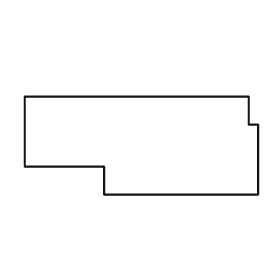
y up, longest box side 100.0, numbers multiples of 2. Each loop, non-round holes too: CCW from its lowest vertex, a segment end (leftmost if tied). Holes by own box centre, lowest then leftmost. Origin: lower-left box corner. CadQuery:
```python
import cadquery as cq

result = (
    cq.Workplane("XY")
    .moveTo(34.0, 0.0)
    .lineTo(100.0, 0.0)
    .lineTo(100.0, 30.0)
    .lineTo(96.0, 30.0)
    .lineTo(96.0, 42.0)
    .lineTo(0.0, 42.0)
    .lineTo(0.0, 12.0)
    .lineTo(34.0, 12.0)
    .close()
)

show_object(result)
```